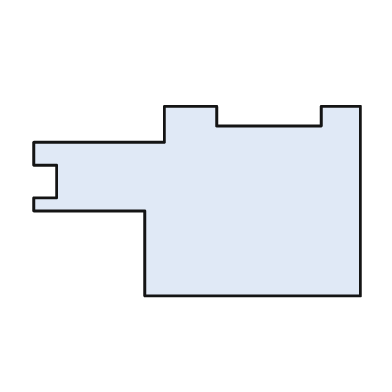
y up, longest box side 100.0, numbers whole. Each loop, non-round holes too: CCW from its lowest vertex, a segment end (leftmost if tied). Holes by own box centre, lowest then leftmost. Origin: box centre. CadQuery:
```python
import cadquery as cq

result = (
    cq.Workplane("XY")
    .moveTo(-16.0, -29.0)
    .lineTo(50.0, -29.0)
    .lineTo(50.0, 29.0)
    .lineTo(38.0, 29.0)
    .lineTo(38.0, 23.0)
    .lineTo(6.0, 23.0)
    .lineTo(6.0, 29.0)
    .lineTo(-10.0, 29.0)
    .lineTo(-10.0, 18.0)
    .lineTo(-50.0, 18.0)
    .lineTo(-50.0, 11.0)
    .lineTo(-43.0, 11.0)
    .lineTo(-43.0, 1.0)
    .lineTo(-50.0, 1.0)
    .lineTo(-50.0, -3.0)
    .lineTo(-16.0, -3.0)
    .close()
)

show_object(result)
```